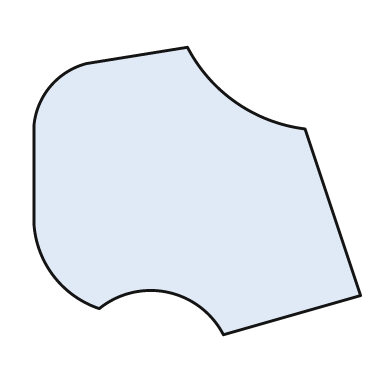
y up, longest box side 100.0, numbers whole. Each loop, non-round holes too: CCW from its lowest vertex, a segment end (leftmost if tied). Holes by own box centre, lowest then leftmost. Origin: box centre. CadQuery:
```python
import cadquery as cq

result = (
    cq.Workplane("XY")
    .moveTo(8.0, -44.0)
    .lineTo(50.0, -32.0)
    .lineTo(33.0, 19.0)
    .threePointArc((12.0, 27.0), (-3.0, 44.0))
    .lineTo(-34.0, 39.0)
    .threePointArc((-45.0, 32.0), (-50.0, 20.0))
    .lineTo(-50.0, -10.0)
    .threePointArc((-44.0, -26.0), (-30.0, -36.0))
    .threePointArc((-9.0, -31.0), (8.0, -44.0))
    .close()
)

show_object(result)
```